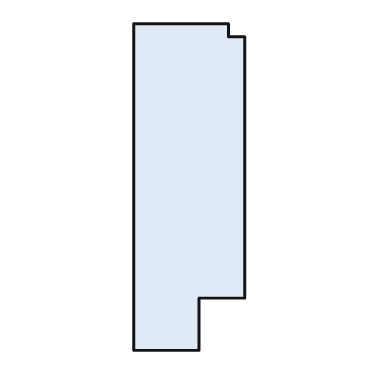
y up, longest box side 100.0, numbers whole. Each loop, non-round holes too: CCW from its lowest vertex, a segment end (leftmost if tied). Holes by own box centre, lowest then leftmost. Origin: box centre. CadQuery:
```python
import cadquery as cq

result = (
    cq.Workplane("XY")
    .moveTo(-17.0, -50.0)
    .lineTo(3.0, -50.0)
    .lineTo(3.0, -34.0)
    .lineTo(17.0, -34.0)
    .lineTo(17.0, 46.0)
    .lineTo(12.0, 46.0)
    .lineTo(12.0, 50.0)
    .lineTo(-17.0, 50.0)
    .close()
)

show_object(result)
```